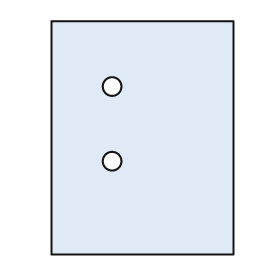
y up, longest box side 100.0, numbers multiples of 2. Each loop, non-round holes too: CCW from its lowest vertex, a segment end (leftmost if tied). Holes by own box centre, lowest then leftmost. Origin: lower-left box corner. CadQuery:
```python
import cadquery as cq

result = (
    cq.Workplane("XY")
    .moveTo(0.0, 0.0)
    .lineTo(78.0, 0.0)
    .lineTo(78.0, 100.0)
    .lineTo(0.0, 100.0)
    .close()
    .moveTo(26.0, 40.0)
    .circle(4.0)
    .moveTo(26.0, 72.0)
    .circle(4.0)
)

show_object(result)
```